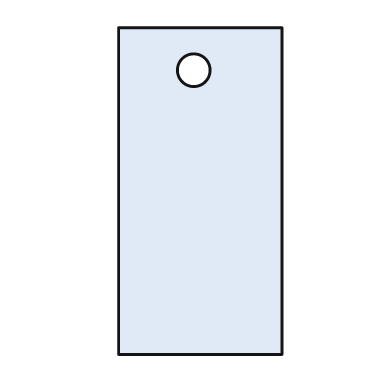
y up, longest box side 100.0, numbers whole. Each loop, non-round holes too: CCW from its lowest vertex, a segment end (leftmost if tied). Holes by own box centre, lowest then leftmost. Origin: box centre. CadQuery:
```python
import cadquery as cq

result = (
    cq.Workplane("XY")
    .moveTo(-25.0, -50.0)
    .lineTo(25.0, -50.0)
    .lineTo(25.0, 50.0)
    .lineTo(-25.0, 50.0)
    .close()
    .moveTo(-2.0, 37.0)
    .circle(5.0)
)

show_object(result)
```